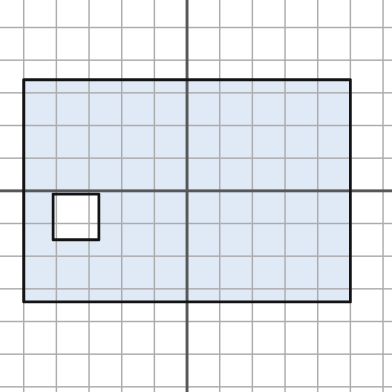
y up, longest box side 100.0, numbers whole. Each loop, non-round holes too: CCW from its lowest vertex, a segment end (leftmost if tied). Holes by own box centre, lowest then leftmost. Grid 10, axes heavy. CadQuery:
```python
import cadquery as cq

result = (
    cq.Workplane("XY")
    .moveTo(-50.0, -34.0)
    .lineTo(50.0, -34.0)
    .lineTo(50.0, 34.0)
    .lineTo(-50.0, 34.0)
    .close()
    .moveTo(-41.0, -15.0)
    .lineTo(-27.0, -15.0)
    .lineTo(-27.0, -1.0)
    .lineTo(-41.0, -1.0)
    .close()
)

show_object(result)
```